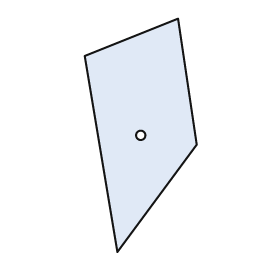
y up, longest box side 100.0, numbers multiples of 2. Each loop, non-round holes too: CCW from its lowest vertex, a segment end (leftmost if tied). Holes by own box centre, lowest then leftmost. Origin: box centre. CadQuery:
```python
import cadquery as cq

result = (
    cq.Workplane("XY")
    .moveTo(-10.0, -50.0)
    .lineTo(24.0, -4.0)
    .lineTo(16.0, 50.0)
    .lineTo(-24.0, 34.0)
    .close()
    .moveTo(0.0, 0.0)
    .circle(2.0)
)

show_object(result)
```